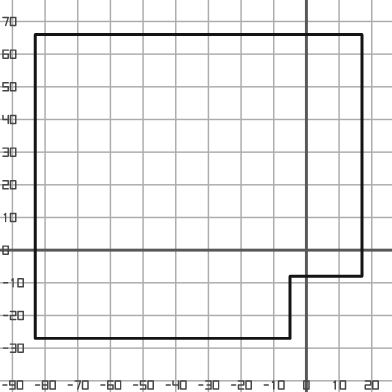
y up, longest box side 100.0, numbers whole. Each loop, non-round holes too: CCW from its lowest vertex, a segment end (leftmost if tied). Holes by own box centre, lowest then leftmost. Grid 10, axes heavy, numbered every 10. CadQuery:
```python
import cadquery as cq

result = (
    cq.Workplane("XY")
    .moveTo(-83.0, -27.0)
    .lineTo(-5.0, -27.0)
    .lineTo(-5.0, -8.0)
    .lineTo(17.0, -8.0)
    .lineTo(17.0, 66.0)
    .lineTo(-83.0, 66.0)
    .close()
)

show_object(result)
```